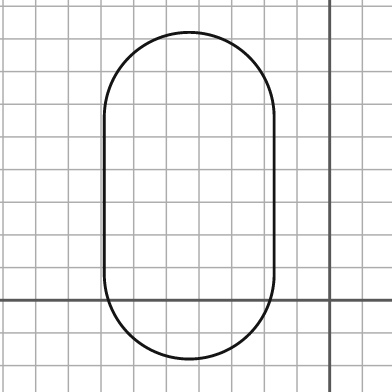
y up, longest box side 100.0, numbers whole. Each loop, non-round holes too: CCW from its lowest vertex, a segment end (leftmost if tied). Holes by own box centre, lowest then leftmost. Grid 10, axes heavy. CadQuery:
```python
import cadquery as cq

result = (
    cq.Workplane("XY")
    .moveTo(-69.0, 8.0)
    .threePointArc((-43.0, -18.0), (-17.0, 8.0))
    .lineTo(-17.0, 56.0)
    .threePointArc((-43.0, 82.0), (-69.0, 56.0))
    .close()
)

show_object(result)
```